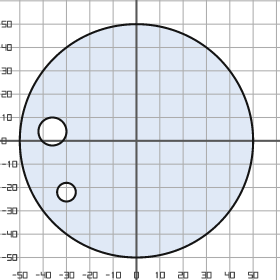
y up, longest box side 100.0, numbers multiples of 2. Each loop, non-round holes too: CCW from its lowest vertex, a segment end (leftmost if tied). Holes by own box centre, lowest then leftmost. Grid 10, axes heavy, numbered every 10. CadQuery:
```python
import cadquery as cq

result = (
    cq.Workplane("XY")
    .moveTo(0.0, 0.0)
    .circle(50.0)
    .moveTo(-30.0, -22.0)
    .circle(4.0)
    .moveTo(-36.0, 4.0)
    .circle(6.0)
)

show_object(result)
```